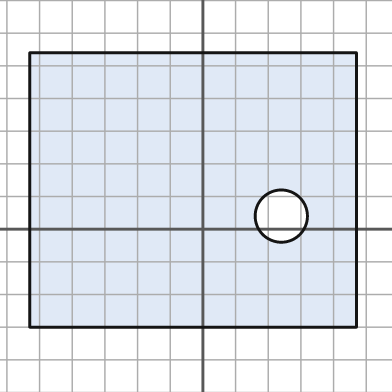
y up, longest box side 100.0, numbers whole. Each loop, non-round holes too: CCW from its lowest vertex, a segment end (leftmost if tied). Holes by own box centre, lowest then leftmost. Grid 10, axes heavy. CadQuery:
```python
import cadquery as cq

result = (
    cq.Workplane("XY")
    .moveTo(-53.0, -30.0)
    .lineTo(47.0, -30.0)
    .lineTo(47.0, 54.0)
    .lineTo(-53.0, 54.0)
    .close()
    .moveTo(24.0, 4.0)
    .circle(8.0)
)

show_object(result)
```